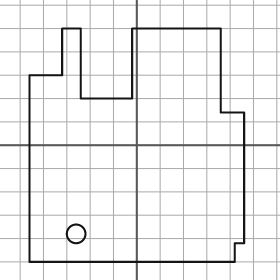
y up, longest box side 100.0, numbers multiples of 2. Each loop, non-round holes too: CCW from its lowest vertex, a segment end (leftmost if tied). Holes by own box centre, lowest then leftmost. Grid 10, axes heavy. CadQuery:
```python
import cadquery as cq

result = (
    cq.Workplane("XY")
    .moveTo(-46.0, -50.0)
    .lineTo(42.0, -50.0)
    .lineTo(42.0, -42.0)
    .lineTo(46.0, -42.0)
    .lineTo(46.0, 14.0)
    .lineTo(36.0, 14.0)
    .lineTo(36.0, 50.0)
    .lineTo(-2.0, 50.0)
    .lineTo(-2.0, 20.0)
    .lineTo(-24.0, 20.0)
    .lineTo(-24.0, 50.0)
    .lineTo(-32.0, 50.0)
    .lineTo(-32.0, 30.0)
    .lineTo(-46.0, 30.0)
    .close()
    .moveTo(-26.0, -38.0)
    .circle(4.0)
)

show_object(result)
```